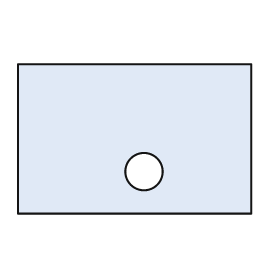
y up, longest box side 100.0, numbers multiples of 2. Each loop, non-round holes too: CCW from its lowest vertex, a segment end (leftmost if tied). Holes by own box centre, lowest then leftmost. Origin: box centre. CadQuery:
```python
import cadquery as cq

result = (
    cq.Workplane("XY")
    .moveTo(-50.0, -32.0)
    .lineTo(50.0, -32.0)
    .lineTo(50.0, 32.0)
    .lineTo(-50.0, 32.0)
    .close()
    .moveTo(4.0, -14.0)
    .circle(8.0)
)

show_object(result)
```